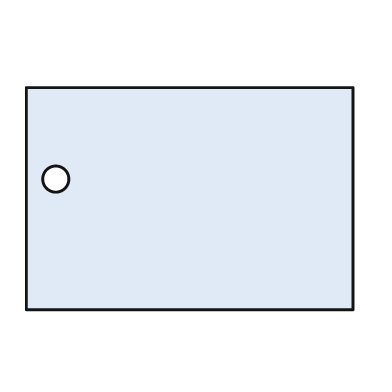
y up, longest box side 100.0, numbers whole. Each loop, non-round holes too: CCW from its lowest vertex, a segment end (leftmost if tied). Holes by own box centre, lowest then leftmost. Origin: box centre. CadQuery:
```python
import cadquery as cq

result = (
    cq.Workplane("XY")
    .moveTo(-50.0, -34.0)
    .lineTo(50.0, -34.0)
    .lineTo(50.0, 34.0)
    .lineTo(-50.0, 34.0)
    .close()
    .moveTo(-41.0, 6.0)
    .circle(4.0)
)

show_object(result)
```